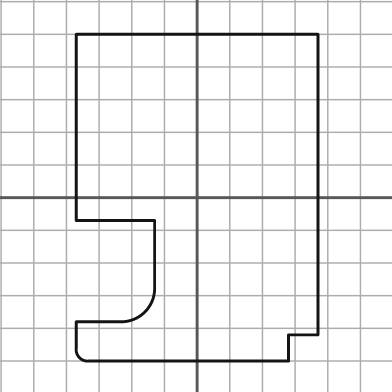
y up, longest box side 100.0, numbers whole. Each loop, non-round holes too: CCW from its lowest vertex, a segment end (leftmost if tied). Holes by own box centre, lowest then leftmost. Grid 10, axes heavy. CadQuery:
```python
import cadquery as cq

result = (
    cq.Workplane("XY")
    .moveTo(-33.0, -50.0)
    .lineTo(28.0, -50.0)
    .lineTo(28.0, -42.0)
    .lineTo(37.0, -42.0)
    .lineTo(37.0, 50.0)
    .lineTo(-37.0, 50.0)
    .lineTo(-37.0, -7.0)
    .lineTo(-13.0, -7.0)
    .lineTo(-13.0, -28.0)
    .threePointArc((-16.0, -35.0), (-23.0, -38.0))
    .lineTo(-37.0, -38.0)
    .lineTo(-37.0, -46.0)
    .threePointArc((-36.0, -49.0), (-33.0, -50.0))
    .close()
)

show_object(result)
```